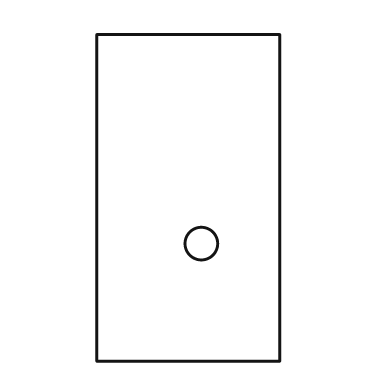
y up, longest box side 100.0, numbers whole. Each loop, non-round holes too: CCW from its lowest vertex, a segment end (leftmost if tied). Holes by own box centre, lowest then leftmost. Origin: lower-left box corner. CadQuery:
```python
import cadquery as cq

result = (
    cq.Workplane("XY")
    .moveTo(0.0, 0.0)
    .lineTo(56.0, 0.0)
    .lineTo(56.0, 100.0)
    .lineTo(0.0, 100.0)
    .close()
    .moveTo(32.0, 36.0)
    .circle(5.0)
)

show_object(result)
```